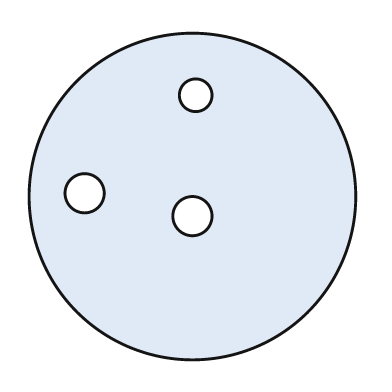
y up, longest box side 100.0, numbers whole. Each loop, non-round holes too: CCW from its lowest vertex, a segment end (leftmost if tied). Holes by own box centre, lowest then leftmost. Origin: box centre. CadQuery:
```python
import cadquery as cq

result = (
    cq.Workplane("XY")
    .moveTo(0.0, 0.0)
    .circle(50.0)
    .moveTo(0.0, -6.0)
    .circle(6.0)
    .moveTo(-33.0, 1.0)
    .circle(6.0)
    .moveTo(1.0, 31.0)
    .circle(5.0)
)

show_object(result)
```